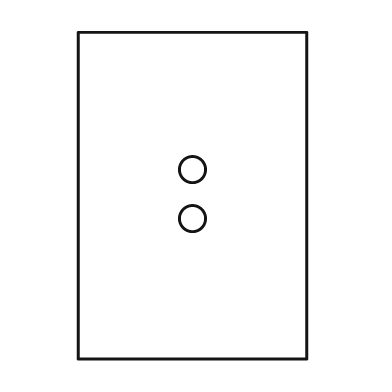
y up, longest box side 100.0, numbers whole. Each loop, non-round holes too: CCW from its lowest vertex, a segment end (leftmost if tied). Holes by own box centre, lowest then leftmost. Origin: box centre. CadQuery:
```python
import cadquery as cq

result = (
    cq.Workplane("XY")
    .moveTo(-35.0, -50.0)
    .lineTo(35.0, -50.0)
    .lineTo(35.0, 50.0)
    .lineTo(-35.0, 50.0)
    .close()
    .moveTo(0.0, -7.0)
    .circle(4.0)
    .moveTo(0.0, 8.0)
    .circle(4.0)
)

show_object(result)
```